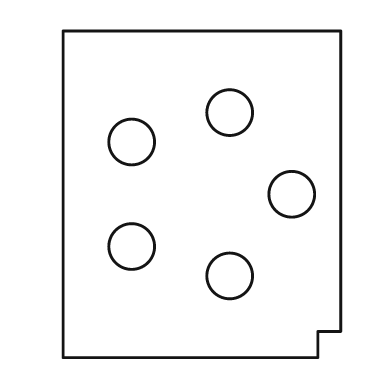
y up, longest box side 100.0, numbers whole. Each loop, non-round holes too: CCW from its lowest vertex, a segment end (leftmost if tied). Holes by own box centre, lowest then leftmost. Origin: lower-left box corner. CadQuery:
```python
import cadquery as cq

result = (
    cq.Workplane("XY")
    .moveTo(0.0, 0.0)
    .lineTo(78.0, 0.0)
    .lineTo(78.0, 8.0)
    .lineTo(85.0, 8.0)
    .lineTo(85.0, 100.0)
    .lineTo(0.0, 100.0)
    .close()
    .moveTo(51.0, 25.0)
    .circle(7.0)
    .moveTo(21.0, 34.0)
    .circle(7.0)
    .moveTo(70.0, 50.0)
    .circle(7.0)
    .moveTo(21.0, 66.0)
    .circle(7.0)
    .moveTo(51.0, 75.0)
    .circle(7.0)
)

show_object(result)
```